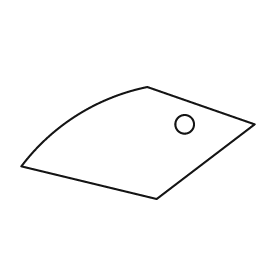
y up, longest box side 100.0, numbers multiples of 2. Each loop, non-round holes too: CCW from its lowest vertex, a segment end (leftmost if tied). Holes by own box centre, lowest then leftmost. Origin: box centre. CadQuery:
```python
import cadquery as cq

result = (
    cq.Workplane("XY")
    .moveTo(8.0, -24.0)
    .lineTo(50.0, 8.0)
    .lineTo(4.0, 24.0)
    .threePointArc((-26.0, 12.0), (-50.0, -10.0))
    .close()
    .moveTo(20.0, 8.0)
    .circle(4.0)
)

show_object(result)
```